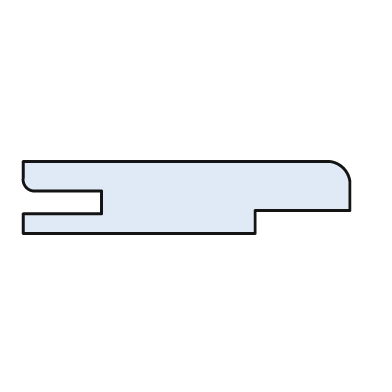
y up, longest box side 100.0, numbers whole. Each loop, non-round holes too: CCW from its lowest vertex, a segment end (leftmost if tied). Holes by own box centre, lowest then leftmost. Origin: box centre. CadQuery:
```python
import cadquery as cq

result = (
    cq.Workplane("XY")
    .moveTo(-50.0, -11.0)
    .lineTo(21.0, -11.0)
    .lineTo(21.0, -4.0)
    .lineTo(50.0, -4.0)
    .lineTo(50.0, 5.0)
    .threePointArc((48.0, 9.0), (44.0, 11.0))
    .lineTo(-50.0, 11.0)
    .lineTo(-50.0, 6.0)
    .threePointArc((-49.0, 3.0), (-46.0, 2.0))
    .lineTo(-26.0, 2.0)
    .lineTo(-26.0, -5.0)
    .lineTo(-50.0, -5.0)
    .close()
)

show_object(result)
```